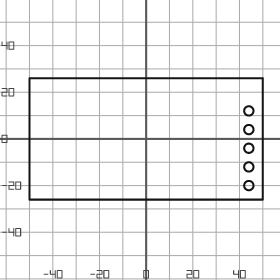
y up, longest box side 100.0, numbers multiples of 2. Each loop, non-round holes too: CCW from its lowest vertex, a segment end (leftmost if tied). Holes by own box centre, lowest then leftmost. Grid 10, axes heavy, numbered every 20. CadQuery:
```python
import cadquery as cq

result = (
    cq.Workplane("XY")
    .moveTo(-50.0, -26.0)
    .lineTo(50.0, -26.0)
    .lineTo(50.0, 26.0)
    .lineTo(-50.0, 26.0)
    .close()
    .moveTo(44.0, -20.0)
    .circle(2.0)
    .moveTo(44.0, -12.0)
    .circle(2.0)
    .moveTo(44.0, -4.0)
    .circle(2.0)
    .moveTo(44.0, 4.0)
    .circle(2.0)
    .moveTo(44.0, 12.0)
    .circle(2.0)
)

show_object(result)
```